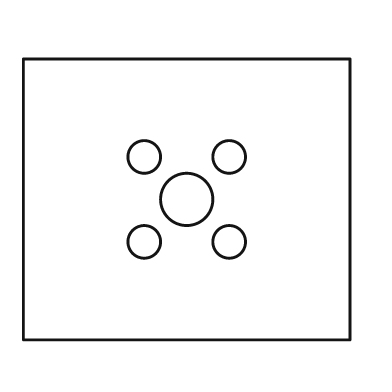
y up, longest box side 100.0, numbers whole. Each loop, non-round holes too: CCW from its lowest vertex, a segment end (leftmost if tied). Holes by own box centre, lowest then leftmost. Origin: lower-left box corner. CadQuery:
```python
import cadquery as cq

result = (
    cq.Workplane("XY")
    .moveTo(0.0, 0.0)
    .lineTo(100.0, 0.0)
    .lineTo(100.0, 86.0)
    .lineTo(0.0, 86.0)
    .close()
    .moveTo(37.0, 30.0)
    .circle(5.0)
    .moveTo(63.0, 30.0)
    .circle(5.0)
    .moveTo(50.0, 43.0)
    .circle(8.0)
    .moveTo(37.0, 56.0)
    .circle(5.0)
    .moveTo(63.0, 56.0)
    .circle(5.0)
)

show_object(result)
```